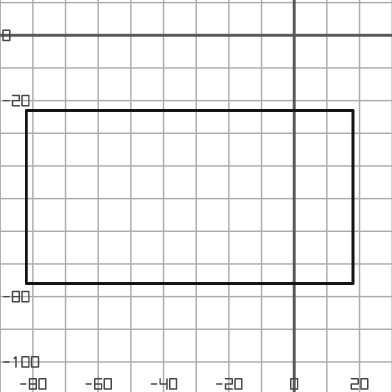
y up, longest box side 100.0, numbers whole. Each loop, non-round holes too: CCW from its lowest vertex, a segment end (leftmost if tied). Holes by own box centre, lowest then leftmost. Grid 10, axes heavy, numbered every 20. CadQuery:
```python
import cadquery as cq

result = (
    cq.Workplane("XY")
    .moveTo(-82.0, -76.0)
    .lineTo(18.0, -76.0)
    .lineTo(18.0, -23.0)
    .lineTo(-82.0, -23.0)
    .close()
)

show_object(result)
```